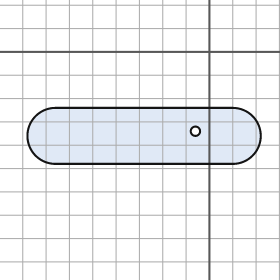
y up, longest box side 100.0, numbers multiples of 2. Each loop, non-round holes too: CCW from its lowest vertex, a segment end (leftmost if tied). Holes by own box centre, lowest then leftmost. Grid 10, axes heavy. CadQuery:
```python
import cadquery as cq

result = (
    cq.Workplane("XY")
    .moveTo(-66.0, -48.0)
    .lineTo(10.0, -48.0)
    .threePointArc((22.0, -36.0), (10.0, -24.0))
    .lineTo(-66.0, -24.0)
    .threePointArc((-78.0, -36.0), (-66.0, -48.0))
    .close()
    .moveTo(-6.0, -34.0)
    .circle(2.0)
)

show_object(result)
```